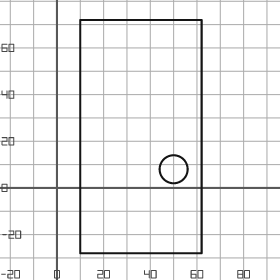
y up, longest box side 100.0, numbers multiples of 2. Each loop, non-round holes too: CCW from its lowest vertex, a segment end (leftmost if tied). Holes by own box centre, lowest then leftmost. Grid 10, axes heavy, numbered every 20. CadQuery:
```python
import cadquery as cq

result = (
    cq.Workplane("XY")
    .moveTo(10.0, -28.0)
    .lineTo(62.0, -28.0)
    .lineTo(62.0, 72.0)
    .lineTo(10.0, 72.0)
    .close()
    .moveTo(50.0, 8.0)
    .circle(6.0)
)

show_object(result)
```